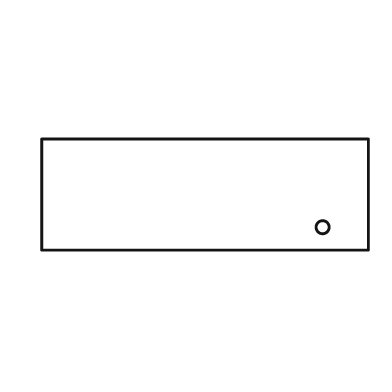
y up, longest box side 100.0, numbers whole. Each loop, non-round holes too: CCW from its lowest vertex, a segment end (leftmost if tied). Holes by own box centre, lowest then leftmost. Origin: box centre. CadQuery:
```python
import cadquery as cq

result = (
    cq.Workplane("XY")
    .moveTo(-50.0, -17.0)
    .lineTo(50.0, -17.0)
    .lineTo(50.0, 17.0)
    .lineTo(-50.0, 17.0)
    .close()
    .moveTo(36.0, -10.0)
    .circle(2.0)
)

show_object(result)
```